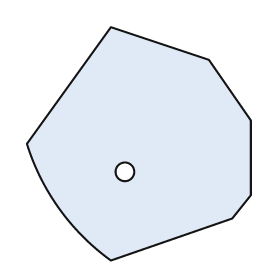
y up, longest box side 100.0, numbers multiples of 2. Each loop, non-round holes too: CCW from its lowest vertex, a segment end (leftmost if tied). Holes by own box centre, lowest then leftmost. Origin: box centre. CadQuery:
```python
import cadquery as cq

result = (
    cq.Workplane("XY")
    .moveTo(-12.0, -50.0)
    .lineTo(40.0, -32.0)
    .lineTo(48.0, -22.0)
    .lineTo(48.0, 10.0)
    .lineTo(30.0, 36.0)
    .lineTo(-12.0, 50.0)
    .lineTo(-48.0, 0.0)
    .threePointArc((-34.0, -28.0), (-12.0, -50.0))
    .close()
    .moveTo(-6.0, -12.0)
    .circle(4.0)
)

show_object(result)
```